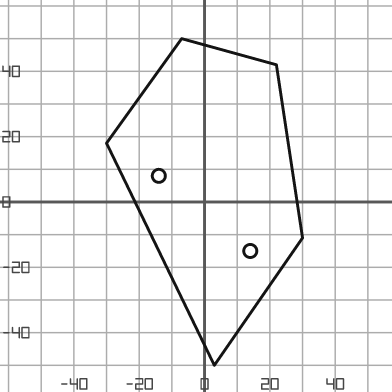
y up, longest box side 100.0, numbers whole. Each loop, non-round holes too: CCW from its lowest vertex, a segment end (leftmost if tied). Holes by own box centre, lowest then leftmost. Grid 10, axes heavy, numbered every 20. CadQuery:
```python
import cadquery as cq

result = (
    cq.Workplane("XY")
    .moveTo(3.0, -50.0)
    .lineTo(30.0, -11.0)
    .lineTo(22.0, 42.0)
    .lineTo(-7.0, 50.0)
    .lineTo(-30.0, 18.0)
    .close()
    .moveTo(14.0, -15.0)
    .circle(2.0)
    .moveTo(-14.0, 8.0)
    .circle(2.0)
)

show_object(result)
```